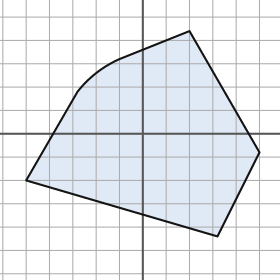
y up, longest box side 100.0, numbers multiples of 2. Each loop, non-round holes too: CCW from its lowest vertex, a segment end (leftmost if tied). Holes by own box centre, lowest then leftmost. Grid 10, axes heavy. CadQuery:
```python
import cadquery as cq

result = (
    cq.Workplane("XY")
    .moveTo(32.0, -44.0)
    .lineTo(50.0, -8.0)
    .lineTo(20.0, 44.0)
    .lineTo(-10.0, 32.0)
    .threePointArc((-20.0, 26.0), (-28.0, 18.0))
    .lineTo(-50.0, -20.0)
    .close()
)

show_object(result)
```